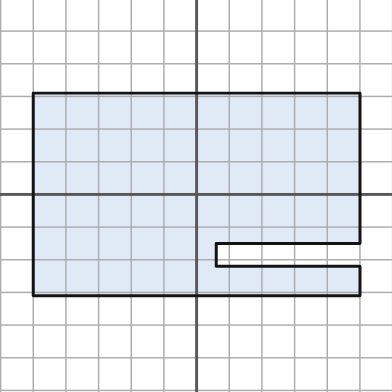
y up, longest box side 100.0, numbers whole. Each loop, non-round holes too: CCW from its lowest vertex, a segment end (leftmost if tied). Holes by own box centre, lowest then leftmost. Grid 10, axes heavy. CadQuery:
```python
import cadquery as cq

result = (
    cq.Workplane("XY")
    .moveTo(-50.0, -31.0)
    .lineTo(50.0, -31.0)
    .lineTo(50.0, -22.0)
    .lineTo(6.0, -22.0)
    .lineTo(6.0, -15.0)
    .lineTo(50.0, -15.0)
    .lineTo(50.0, 31.0)
    .lineTo(-50.0, 31.0)
    .close()
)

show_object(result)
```